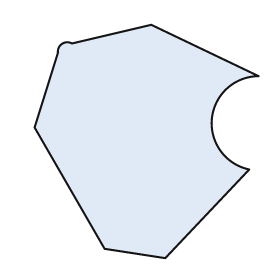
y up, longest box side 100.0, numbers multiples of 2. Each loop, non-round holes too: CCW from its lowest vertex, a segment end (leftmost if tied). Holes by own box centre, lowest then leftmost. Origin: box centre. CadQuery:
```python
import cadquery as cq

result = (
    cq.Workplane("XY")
    .moveTo(8.0, -50.0)
    .lineTo(44.0, -12.0)
    .threePointArc((28.0, 10.0), (48.0, 28.0))
    .lineTo(2.0, 50.0)
    .lineTo(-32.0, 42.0)
    .threePointArc((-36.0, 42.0), (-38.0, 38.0))
    .lineTo(-48.0, 6.0)
    .lineTo(-18.0, -46.0)
    .close()
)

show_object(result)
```